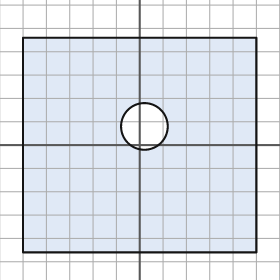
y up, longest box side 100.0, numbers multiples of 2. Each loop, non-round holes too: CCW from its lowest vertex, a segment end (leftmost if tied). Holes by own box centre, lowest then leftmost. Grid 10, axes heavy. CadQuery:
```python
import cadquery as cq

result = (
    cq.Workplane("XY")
    .moveTo(-50.0, -46.0)
    .lineTo(50.0, -46.0)
    .lineTo(50.0, 46.0)
    .lineTo(-50.0, 46.0)
    .close()
    .moveTo(2.0, 8.0)
    .circle(10.0)
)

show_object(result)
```